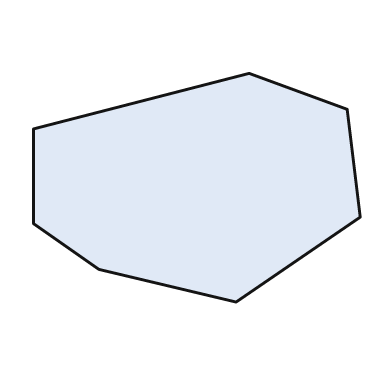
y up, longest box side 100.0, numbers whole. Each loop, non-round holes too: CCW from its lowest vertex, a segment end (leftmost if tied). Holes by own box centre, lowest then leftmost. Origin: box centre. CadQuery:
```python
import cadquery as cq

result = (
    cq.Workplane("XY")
    .moveTo(12.0, -35.0)
    .lineTo(50.0, -9.0)
    .lineTo(46.0, 24.0)
    .lineTo(16.0, 35.0)
    .lineTo(-50.0, 18.0)
    .lineTo(-50.0, -11.0)
    .lineTo(-30.0, -25.0)
    .close()
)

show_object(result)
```